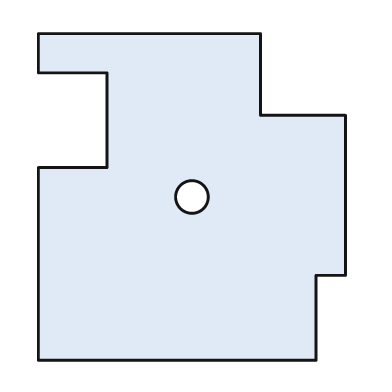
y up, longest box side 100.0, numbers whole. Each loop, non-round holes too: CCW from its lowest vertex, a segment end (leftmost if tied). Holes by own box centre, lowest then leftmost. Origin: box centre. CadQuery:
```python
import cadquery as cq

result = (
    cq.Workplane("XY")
    .moveTo(-47.0, -50.0)
    .lineTo(38.0, -50.0)
    .lineTo(38.0, -24.0)
    .lineTo(47.0, -24.0)
    .lineTo(47.0, 25.0)
    .lineTo(21.0, 25.0)
    .lineTo(21.0, 50.0)
    .lineTo(-47.0, 50.0)
    .lineTo(-47.0, 38.0)
    .lineTo(-26.0, 38.0)
    .lineTo(-26.0, 9.0)
    .lineTo(-47.0, 9.0)
    .close()
    .moveTo(0.0, 0.0)
    .circle(5.0)
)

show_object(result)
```